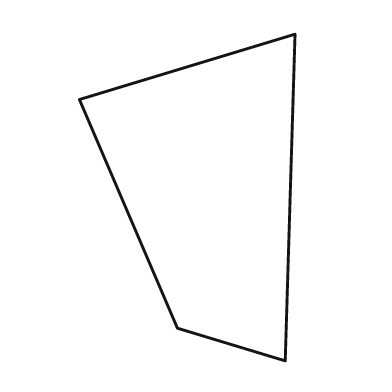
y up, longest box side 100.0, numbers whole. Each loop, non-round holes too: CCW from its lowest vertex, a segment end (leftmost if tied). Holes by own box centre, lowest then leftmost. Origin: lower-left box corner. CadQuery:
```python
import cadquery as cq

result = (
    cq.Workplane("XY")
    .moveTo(63.0, 0.0)
    .lineTo(66.0, 100.0)
    .lineTo(0.0, 80.0)
    .lineTo(30.0, 10.0)
    .close()
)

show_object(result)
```